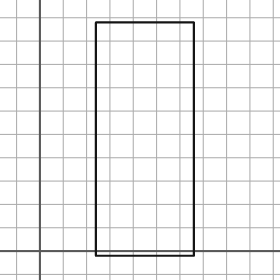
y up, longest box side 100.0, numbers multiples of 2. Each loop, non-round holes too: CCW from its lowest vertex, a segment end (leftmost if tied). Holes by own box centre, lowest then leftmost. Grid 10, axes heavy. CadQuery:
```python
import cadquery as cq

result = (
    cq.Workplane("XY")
    .moveTo(24.0, -2.0)
    .lineTo(66.0, -2.0)
    .lineTo(66.0, 98.0)
    .lineTo(24.0, 98.0)
    .close()
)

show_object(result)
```